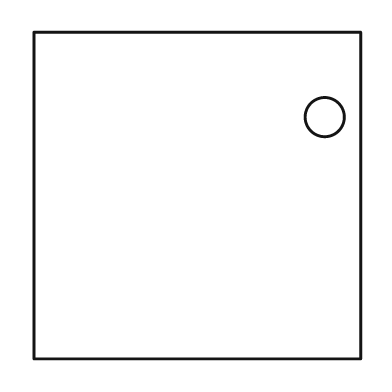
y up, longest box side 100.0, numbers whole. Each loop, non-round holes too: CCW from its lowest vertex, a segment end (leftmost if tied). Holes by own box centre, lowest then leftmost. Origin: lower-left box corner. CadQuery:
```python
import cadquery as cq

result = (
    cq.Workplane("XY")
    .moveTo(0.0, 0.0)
    .lineTo(100.0, 0.0)
    .lineTo(100.0, 100.0)
    .lineTo(0.0, 100.0)
    .close()
    .moveTo(89.0, 74.0)
    .circle(6.0)
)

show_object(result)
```